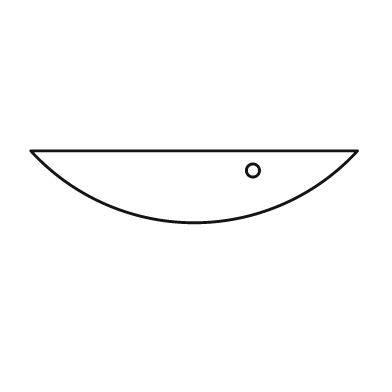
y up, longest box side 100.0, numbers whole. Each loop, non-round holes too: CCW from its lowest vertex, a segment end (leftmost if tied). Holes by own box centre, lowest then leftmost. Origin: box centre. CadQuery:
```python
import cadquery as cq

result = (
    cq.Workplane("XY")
    .moveTo(-50.0, 11.0)
    .threePointArc((0.0, -11.0), (50.0, 11.0))
    .close()
    .moveTo(18.0, 5.0)
    .circle(2.0)
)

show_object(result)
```